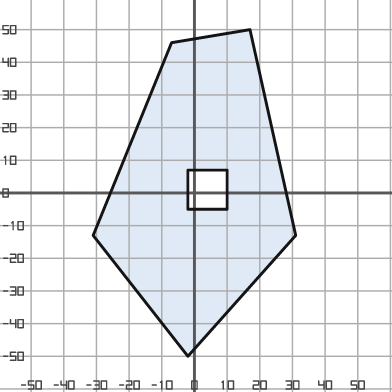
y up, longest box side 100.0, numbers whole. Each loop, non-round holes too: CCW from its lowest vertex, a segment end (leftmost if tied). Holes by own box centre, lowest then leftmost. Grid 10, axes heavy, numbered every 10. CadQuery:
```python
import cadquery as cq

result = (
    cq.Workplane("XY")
    .moveTo(-2.0, -50.0)
    .lineTo(31.0, -13.0)
    .lineTo(17.0, 50.0)
    .lineTo(-7.0, 46.0)
    .lineTo(-31.0, -13.0)
    .close()
    .moveTo(-2.0, -5.0)
    .lineTo(10.0, -5.0)
    .lineTo(10.0, 7.0)
    .lineTo(-2.0, 7.0)
    .close()
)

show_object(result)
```